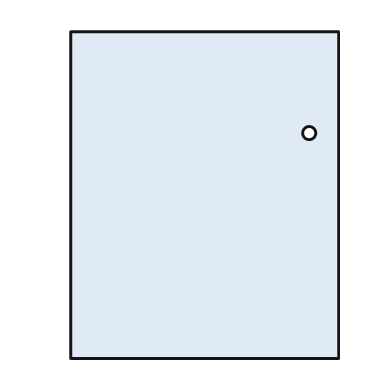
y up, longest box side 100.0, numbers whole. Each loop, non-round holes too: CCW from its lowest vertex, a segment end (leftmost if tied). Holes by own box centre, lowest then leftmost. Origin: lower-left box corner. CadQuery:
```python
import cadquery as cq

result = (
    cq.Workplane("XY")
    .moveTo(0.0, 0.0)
    .lineTo(82.0, 0.0)
    .lineTo(82.0, 100.0)
    .lineTo(0.0, 100.0)
    .close()
    .moveTo(73.0, 69.0)
    .circle(2.0)
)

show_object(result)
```